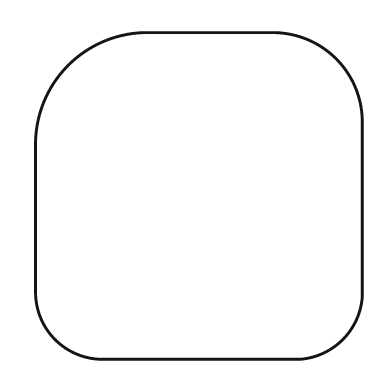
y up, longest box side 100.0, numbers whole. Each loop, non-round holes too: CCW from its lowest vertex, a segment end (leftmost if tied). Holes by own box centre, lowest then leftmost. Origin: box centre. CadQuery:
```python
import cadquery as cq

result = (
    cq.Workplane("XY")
    .moveTo(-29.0, -50.0)
    .lineTo(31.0, -50.0)
    .threePointArc((44.0, -44.0), (50.0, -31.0))
    .lineTo(50.0, 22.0)
    .threePointArc((42.0, 42.0), (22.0, 50.0))
    .lineTo(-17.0, 50.0)
    .threePointArc((-40.0, 40.0), (-50.0, 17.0))
    .lineTo(-50.0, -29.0)
    .threePointArc((-44.0, -44.0), (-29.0, -50.0))
    .close()
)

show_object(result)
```